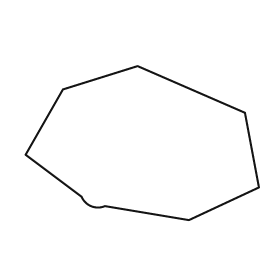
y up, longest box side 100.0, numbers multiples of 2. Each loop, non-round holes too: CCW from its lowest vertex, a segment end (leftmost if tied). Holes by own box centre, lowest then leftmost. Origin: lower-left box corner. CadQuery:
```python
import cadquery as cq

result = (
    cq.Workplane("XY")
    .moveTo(70.0, 0.0)
    .lineTo(100.0, 14.0)
    .lineTo(94.0, 46.0)
    .lineTo(48.0, 66.0)
    .lineTo(16.0, 56.0)
    .lineTo(0.0, 28.0)
    .lineTo(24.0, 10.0)
    .threePointArc((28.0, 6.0), (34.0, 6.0))
    .close()
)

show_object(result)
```